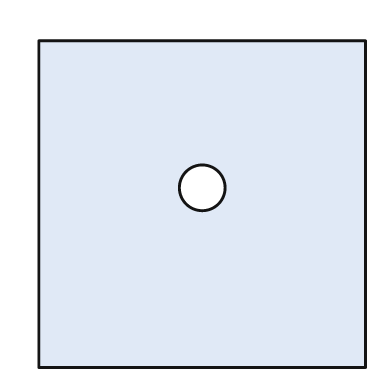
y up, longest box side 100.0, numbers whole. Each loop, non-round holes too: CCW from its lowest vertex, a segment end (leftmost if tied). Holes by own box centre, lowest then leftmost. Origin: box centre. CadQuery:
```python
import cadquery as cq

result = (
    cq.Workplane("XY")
    .moveTo(-50.0, -50.0)
    .lineTo(50.0, -50.0)
    .lineTo(50.0, 50.0)
    .lineTo(-50.0, 50.0)
    .close()
    .moveTo(0.0, 5.0)
    .circle(7.0)
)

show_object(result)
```